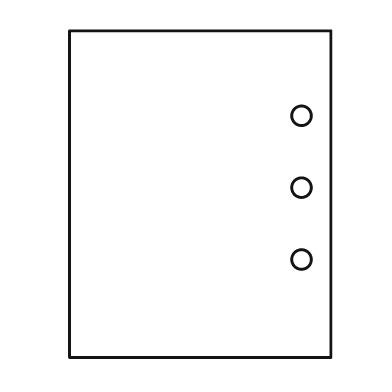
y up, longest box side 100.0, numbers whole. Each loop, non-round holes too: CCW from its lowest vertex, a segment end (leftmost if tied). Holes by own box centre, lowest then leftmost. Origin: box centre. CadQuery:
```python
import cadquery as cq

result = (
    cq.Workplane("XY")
    .moveTo(-40.0, -50.0)
    .lineTo(40.0, -50.0)
    .lineTo(40.0, 50.0)
    .lineTo(-40.0, 50.0)
    .close()
    .moveTo(31.0, -20.0)
    .circle(3.0)
    .moveTo(31.0, 2.0)
    .circle(3.0)
    .moveTo(31.0, 24.0)
    .circle(3.0)
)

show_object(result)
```